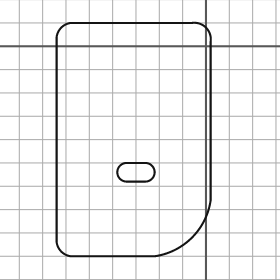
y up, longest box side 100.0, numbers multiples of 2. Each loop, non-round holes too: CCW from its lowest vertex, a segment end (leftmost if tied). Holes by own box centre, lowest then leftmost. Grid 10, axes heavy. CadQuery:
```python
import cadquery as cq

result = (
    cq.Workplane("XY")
    .moveTo(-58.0, -90.0)
    .lineTo(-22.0, -90.0)
    .threePointArc((-6.0, -82.0), (2.0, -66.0))
    .lineTo(2.0, 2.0)
    .threePointArc((0.0, 8.0), (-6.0, 10.0))
    .lineTo(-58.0, 10.0)
    .threePointArc((-62.0, 8.0), (-64.0, 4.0))
    .lineTo(-64.0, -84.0)
    .threePointArc((-62.0, -88.0), (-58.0, -90.0))
    .close()
    .moveTo(-34.0, -58.0)
    .lineTo(-26.0, -58.0)
    .threePointArc((-22.0, -54.0), (-26.0, -50.0))
    .lineTo(-34.0, -50.0)
    .threePointArc((-38.0, -54.0), (-34.0, -58.0))
    .close()
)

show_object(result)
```